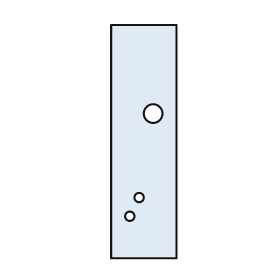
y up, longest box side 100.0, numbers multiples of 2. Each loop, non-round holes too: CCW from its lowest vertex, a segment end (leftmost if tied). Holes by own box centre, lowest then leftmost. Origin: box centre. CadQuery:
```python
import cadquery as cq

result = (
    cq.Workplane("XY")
    .moveTo(-14.0, -50.0)
    .lineTo(14.0, -50.0)
    .lineTo(14.0, 50.0)
    .lineTo(-14.0, 50.0)
    .close()
    .moveTo(-6.0, -32.0)
    .circle(2.0)
    .moveTo(-2.0, -24.0)
    .circle(2.0)
    .moveTo(4.0, 12.0)
    .circle(4.0)
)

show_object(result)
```